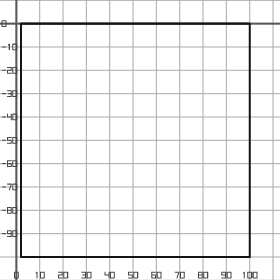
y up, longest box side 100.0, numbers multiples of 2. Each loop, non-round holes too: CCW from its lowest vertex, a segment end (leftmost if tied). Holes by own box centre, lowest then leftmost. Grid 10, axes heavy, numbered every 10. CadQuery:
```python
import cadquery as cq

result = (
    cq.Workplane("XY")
    .moveTo(2.0, -100.0)
    .lineTo(100.0, -100.0)
    .lineTo(100.0, 0.0)
    .lineTo(2.0, 0.0)
    .close()
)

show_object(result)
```